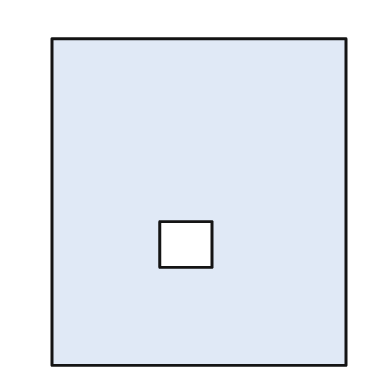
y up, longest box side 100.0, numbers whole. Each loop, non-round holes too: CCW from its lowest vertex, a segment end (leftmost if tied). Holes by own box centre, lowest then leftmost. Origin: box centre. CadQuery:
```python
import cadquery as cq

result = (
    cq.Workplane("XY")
    .moveTo(-45.0, -50.0)
    .lineTo(45.0, -50.0)
    .lineTo(45.0, 50.0)
    .lineTo(-45.0, 50.0)
    .close()
    .moveTo(-12.0, -20.0)
    .lineTo(4.0, -20.0)
    .lineTo(4.0, -6.0)
    .lineTo(-12.0, -6.0)
    .close()
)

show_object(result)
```